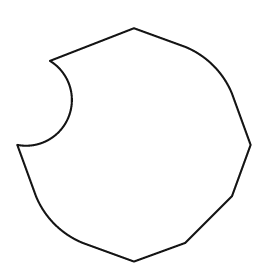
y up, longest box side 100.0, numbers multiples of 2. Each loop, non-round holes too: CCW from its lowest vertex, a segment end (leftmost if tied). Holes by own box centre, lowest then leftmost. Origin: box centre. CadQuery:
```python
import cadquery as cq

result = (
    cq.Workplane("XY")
    .moveTo(0.0, -50.0)
    .lineTo(22.0, -42.0)
    .lineTo(42.0, -22.0)
    .lineTo(50.0, 0.0)
    .lineTo(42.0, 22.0)
    .threePointArc((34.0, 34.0), (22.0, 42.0))
    .lineTo(0.0, 50.0)
    .lineTo(-36.0, 36.0)
    .threePointArc((-28.0, 12.0), (-50.0, 0.0))
    .lineTo(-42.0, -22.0)
    .threePointArc((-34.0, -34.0), (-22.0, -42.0))
    .close()
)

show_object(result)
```